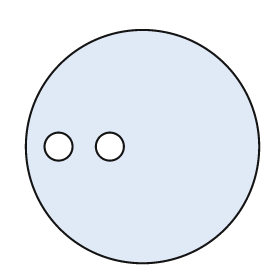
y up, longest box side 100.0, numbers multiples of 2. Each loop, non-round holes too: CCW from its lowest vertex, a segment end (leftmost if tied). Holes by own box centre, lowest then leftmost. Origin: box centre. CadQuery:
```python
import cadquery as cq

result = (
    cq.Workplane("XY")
    .moveTo(0.0, 0.0)
    .circle(50.0)
    .moveTo(-36.0, 0.0)
    .circle(6.0)
    .moveTo(-14.0, 0.0)
    .circle(6.0)
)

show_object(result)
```